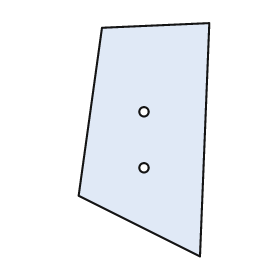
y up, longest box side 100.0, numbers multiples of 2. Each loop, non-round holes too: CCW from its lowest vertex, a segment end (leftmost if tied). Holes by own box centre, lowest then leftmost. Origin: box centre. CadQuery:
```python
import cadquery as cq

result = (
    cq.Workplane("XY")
    .moveTo(24.0, -50.0)
    .lineTo(28.0, 50.0)
    .lineTo(-18.0, 48.0)
    .lineTo(-28.0, -24.0)
    .close()
    .moveTo(0.0, -12.0)
    .circle(2.0)
    .moveTo(0.0, 12.0)
    .circle(2.0)
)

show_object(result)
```